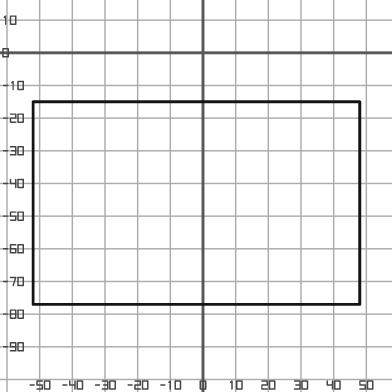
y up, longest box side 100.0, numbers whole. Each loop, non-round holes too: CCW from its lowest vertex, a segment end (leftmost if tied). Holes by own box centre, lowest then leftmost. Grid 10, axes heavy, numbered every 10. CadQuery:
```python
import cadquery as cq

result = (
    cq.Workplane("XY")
    .moveTo(-52.0, -77.0)
    .lineTo(48.0, -77.0)
    .lineTo(48.0, -15.0)
    .lineTo(-52.0, -15.0)
    .close()
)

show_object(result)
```